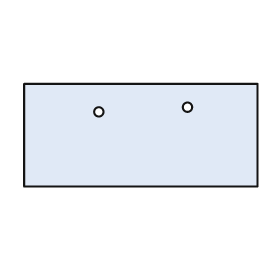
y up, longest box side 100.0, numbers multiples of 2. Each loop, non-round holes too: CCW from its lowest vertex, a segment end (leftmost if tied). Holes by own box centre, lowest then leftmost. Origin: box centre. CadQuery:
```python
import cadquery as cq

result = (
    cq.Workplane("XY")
    .moveTo(-50.0, -22.0)
    .lineTo(50.0, -22.0)
    .lineTo(50.0, 22.0)
    .lineTo(-50.0, 22.0)
    .close()
    .moveTo(-18.0, 10.0)
    .circle(2.0)
    .moveTo(20.0, 12.0)
    .circle(2.0)
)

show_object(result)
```